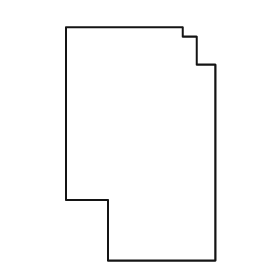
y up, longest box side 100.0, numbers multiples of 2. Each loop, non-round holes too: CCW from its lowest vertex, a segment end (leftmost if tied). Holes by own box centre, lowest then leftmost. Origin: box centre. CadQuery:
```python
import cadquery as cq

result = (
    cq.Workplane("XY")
    .moveTo(-14.0, -50.0)
    .lineTo(32.0, -50.0)
    .lineTo(32.0, 34.0)
    .lineTo(24.0, 34.0)
    .lineTo(24.0, 46.0)
    .lineTo(18.0, 46.0)
    .lineTo(18.0, 50.0)
    .lineTo(-32.0, 50.0)
    .lineTo(-32.0, -24.0)
    .lineTo(-14.0, -24.0)
    .close()
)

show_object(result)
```